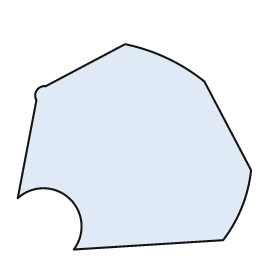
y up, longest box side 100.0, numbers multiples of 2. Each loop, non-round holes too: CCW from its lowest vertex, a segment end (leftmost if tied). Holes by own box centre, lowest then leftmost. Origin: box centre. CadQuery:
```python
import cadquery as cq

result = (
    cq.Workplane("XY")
    .moveTo(-26.0, -44.0)
    .lineTo(38.0, -40.0)
    .threePointArc((46.0, -26.0), (50.0, -10.0))
    .lineTo(30.0, 28.0)
    .threePointArc((14.0, 38.0), (-4.0, 44.0))
    .lineTo(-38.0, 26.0)
    .threePointArc((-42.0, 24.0), (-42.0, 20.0))
    .lineTo(-50.0, -22.0)
    .threePointArc((-28.0, -22.0), (-26.0, -44.0))
    .close()
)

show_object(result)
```